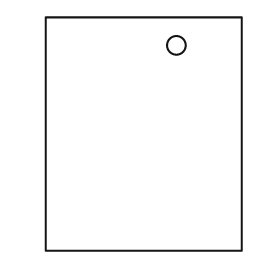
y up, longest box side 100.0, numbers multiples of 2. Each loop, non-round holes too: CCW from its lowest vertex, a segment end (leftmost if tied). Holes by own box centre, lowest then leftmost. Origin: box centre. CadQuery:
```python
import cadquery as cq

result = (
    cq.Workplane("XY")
    .moveTo(-42.0, -50.0)
    .lineTo(42.0, -50.0)
    .lineTo(42.0, 50.0)
    .lineTo(-42.0, 50.0)
    .close()
    .moveTo(14.0, 38.0)
    .circle(4.0)
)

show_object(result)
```